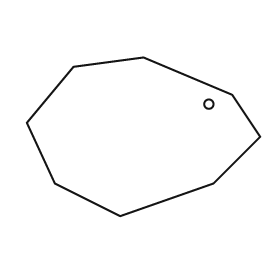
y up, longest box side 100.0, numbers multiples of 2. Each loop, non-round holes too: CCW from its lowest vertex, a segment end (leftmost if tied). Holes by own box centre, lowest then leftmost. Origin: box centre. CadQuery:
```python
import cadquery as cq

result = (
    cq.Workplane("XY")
    .moveTo(-10.0, -34.0)
    .lineTo(30.0, -20.0)
    .lineTo(50.0, 0.0)
    .lineTo(38.0, 18.0)
    .lineTo(0.0, 34.0)
    .lineTo(-30.0, 30.0)
    .lineTo(-50.0, 6.0)
    .lineTo(-38.0, -20.0)
    .close()
    .moveTo(28.0, 14.0)
    .circle(2.0)
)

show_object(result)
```